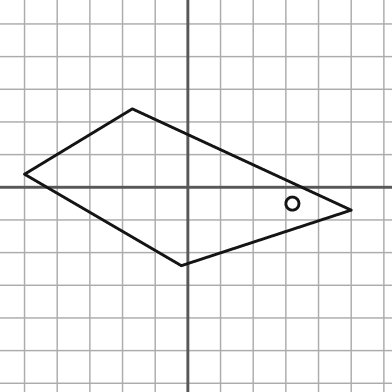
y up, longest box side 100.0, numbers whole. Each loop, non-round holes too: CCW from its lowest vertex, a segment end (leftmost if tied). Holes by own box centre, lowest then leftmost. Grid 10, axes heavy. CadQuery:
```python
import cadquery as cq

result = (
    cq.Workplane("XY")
    .moveTo(-2.0, -24.0)
    .lineTo(50.0, -7.0)
    .lineTo(-17.0, 24.0)
    .lineTo(-50.0, 4.0)
    .close()
    .moveTo(32.0, -5.0)
    .circle(2.0)
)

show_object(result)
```